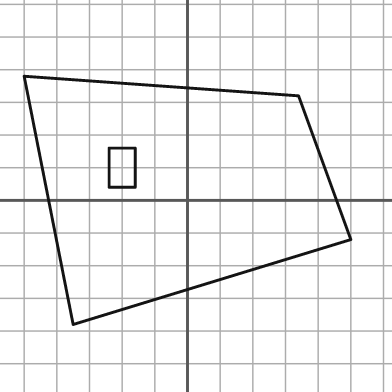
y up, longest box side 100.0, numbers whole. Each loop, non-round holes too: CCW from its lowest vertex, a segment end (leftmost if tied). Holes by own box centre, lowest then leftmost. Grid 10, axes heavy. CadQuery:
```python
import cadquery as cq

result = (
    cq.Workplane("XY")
    .moveTo(-35.0, -38.0)
    .lineTo(50.0, -12.0)
    .lineTo(34.0, 32.0)
    .lineTo(-50.0, 38.0)
    .close()
    .moveTo(-24.0, 4.0)
    .lineTo(-16.0, 4.0)
    .lineTo(-16.0, 16.0)
    .lineTo(-24.0, 16.0)
    .close()
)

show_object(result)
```